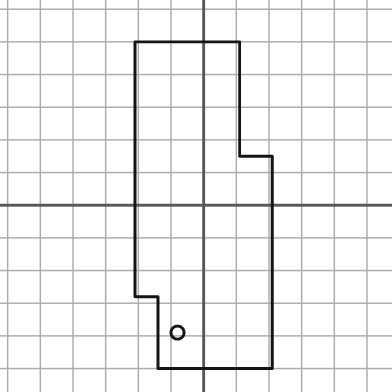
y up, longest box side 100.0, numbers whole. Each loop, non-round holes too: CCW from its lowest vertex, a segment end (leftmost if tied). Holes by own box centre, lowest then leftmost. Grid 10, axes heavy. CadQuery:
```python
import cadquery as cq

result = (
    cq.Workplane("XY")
    .moveTo(-14.0, -50.0)
    .lineTo(21.0, -50.0)
    .lineTo(21.0, 15.0)
    .lineTo(11.0, 15.0)
    .lineTo(11.0, 50.0)
    .lineTo(-21.0, 50.0)
    .lineTo(-21.0, -28.0)
    .lineTo(-14.0, -28.0)
    .close()
    .moveTo(-8.0, -39.0)
    .circle(2.0)
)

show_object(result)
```